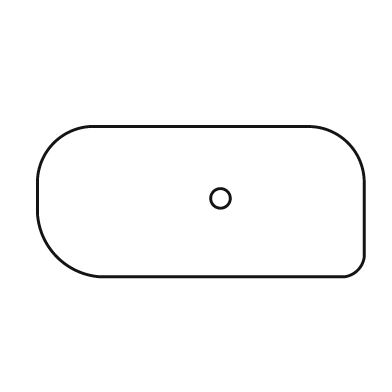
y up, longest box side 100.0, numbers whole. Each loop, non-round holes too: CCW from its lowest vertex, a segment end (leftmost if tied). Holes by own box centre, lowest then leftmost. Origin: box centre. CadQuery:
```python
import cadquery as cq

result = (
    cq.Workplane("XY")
    .moveTo(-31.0, -23.0)
    .lineTo(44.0, -23.0)
    .threePointArc((48.0, -21.0), (50.0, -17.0))
    .lineTo(50.0, 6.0)
    .threePointArc((45.0, 18.0), (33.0, 23.0))
    .lineTo(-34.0, 23.0)
    .threePointArc((-45.0, 18.0), (-50.0, 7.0))
    .lineTo(-50.0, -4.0)
    .threePointArc((-44.0, -17.0), (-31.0, -23.0))
    .close()
    .moveTo(6.0, 1.0)
    .circle(3.0)
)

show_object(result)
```